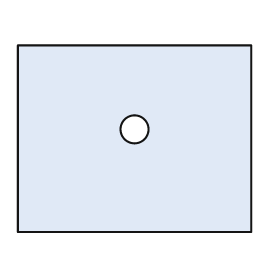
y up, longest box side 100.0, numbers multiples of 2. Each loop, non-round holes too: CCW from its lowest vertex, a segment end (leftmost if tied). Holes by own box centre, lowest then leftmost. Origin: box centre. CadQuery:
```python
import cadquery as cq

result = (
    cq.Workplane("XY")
    .moveTo(-50.0, -40.0)
    .lineTo(50.0, -40.0)
    .lineTo(50.0, 40.0)
    .lineTo(-50.0, 40.0)
    .close()
    .moveTo(0.0, 4.0)
    .circle(6.0)
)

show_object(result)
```